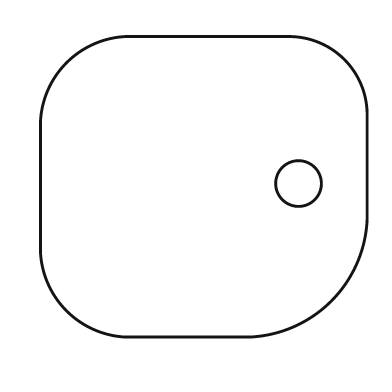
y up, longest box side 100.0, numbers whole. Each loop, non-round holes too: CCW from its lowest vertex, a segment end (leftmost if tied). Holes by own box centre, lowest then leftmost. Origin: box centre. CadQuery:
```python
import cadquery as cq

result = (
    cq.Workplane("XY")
    .moveTo(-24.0, -46.0)
    .lineTo(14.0, -46.0)
    .threePointArc((39.0, -35.0), (50.0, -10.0))
    .lineTo(50.0, 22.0)
    .threePointArc((43.0, 39.0), (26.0, 46.0))
    .lineTo(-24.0, 46.0)
    .threePointArc((-42.0, 38.0), (-50.0, 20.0))
    .lineTo(-50.0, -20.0)
    .threePointArc((-42.0, -38.0), (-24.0, -46.0))
    .close()
    .moveTo(29.0, 1.0)
    .circle(7.0)
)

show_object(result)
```